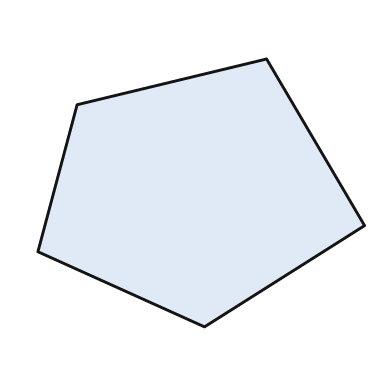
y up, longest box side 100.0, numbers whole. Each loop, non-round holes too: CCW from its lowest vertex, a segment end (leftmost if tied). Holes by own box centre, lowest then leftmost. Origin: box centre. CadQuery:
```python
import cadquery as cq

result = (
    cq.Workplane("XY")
    .moveTo(1.0, -41.0)
    .lineTo(50.0, -10.0)
    .lineTo(20.0, 41.0)
    .lineTo(-38.0, 27.0)
    .lineTo(-50.0, -18.0)
    .close()
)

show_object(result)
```